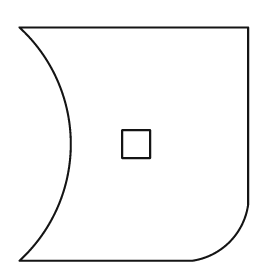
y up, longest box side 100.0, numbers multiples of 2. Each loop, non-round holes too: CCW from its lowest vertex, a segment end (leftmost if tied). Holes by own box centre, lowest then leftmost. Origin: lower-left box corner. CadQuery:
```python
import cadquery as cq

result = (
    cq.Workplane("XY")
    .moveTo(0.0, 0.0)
    .lineTo(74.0, 0.0)
    .threePointArc((90.0, 8.0), (98.0, 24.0))
    .lineTo(98.0, 100.0)
    .lineTo(0.0, 100.0)
    .threePointArc((22.0, 50.0), (0.0, 0.0))
    .close()
    .moveTo(44.0, 44.0)
    .lineTo(56.0, 44.0)
    .lineTo(56.0, 56.0)
    .lineTo(44.0, 56.0)
    .close()
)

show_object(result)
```